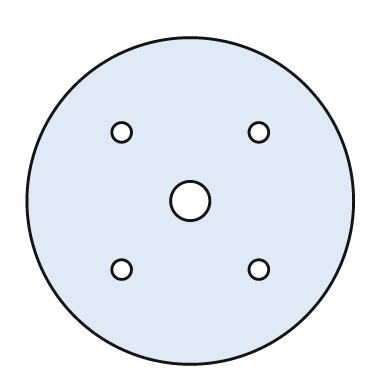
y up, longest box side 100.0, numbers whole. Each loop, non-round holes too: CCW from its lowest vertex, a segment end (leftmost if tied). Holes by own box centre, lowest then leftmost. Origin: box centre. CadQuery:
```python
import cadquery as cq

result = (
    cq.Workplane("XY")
    .moveTo(0.0, 0.0)
    .circle(50.0)
    .moveTo(-21.0, -21.0)
    .circle(3.0)
    .moveTo(21.0, -21.0)
    .circle(3.0)
    .moveTo(0.0, 0.0)
    .circle(6.0)
    .moveTo(-21.0, 21.0)
    .circle(3.0)
    .moveTo(21.0, 21.0)
    .circle(3.0)
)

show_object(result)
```